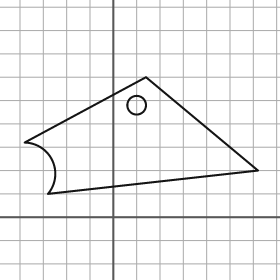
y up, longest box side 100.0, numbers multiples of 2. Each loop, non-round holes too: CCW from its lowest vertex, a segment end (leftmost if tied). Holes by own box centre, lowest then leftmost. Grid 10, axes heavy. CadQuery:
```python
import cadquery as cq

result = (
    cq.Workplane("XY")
    .moveTo(-28.0, 10.0)
    .lineTo(62.0, 20.0)
    .lineTo(14.0, 60.0)
    .lineTo(-38.0, 32.0)
    .threePointArc((-26.0, 24.0), (-28.0, 10.0))
    .close()
    .moveTo(10.0, 48.0)
    .circle(4.0)
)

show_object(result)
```